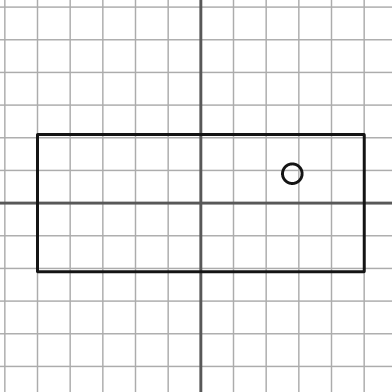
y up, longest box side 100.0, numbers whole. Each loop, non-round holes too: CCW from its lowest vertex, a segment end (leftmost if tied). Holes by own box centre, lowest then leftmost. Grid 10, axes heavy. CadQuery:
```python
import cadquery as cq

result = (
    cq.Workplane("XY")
    .moveTo(-50.0, -21.0)
    .lineTo(50.0, -21.0)
    .lineTo(50.0, 21.0)
    .lineTo(-50.0, 21.0)
    .close()
    .moveTo(28.0, 9.0)
    .circle(3.0)
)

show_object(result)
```